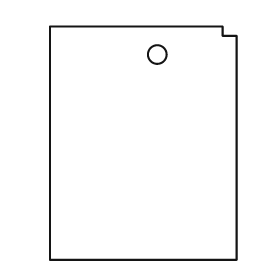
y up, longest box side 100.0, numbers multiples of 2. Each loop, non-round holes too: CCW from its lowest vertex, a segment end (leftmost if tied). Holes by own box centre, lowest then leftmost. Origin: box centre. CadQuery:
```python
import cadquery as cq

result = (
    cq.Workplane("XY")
    .moveTo(-40.0, -50.0)
    .lineTo(40.0, -50.0)
    .lineTo(40.0, 46.0)
    .lineTo(34.0, 46.0)
    .lineTo(34.0, 50.0)
    .lineTo(-40.0, 50.0)
    .close()
    .moveTo(6.0, 38.0)
    .circle(4.0)
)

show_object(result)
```